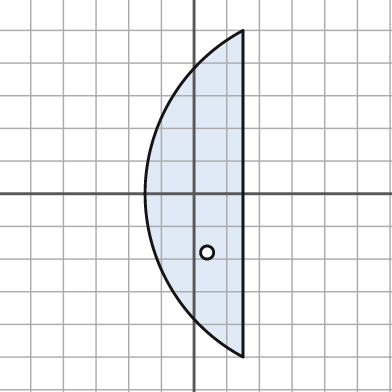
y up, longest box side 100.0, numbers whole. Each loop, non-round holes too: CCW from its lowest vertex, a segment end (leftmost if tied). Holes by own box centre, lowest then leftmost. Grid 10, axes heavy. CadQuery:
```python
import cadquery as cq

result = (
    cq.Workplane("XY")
    .moveTo(15.0, -50.0)
    .lineTo(15.0, 50.0)
    .threePointArc((-15.0, 0.0), (15.0, -50.0))
    .close()
    .moveTo(4.0, -18.0)
    .circle(2.0)
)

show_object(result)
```